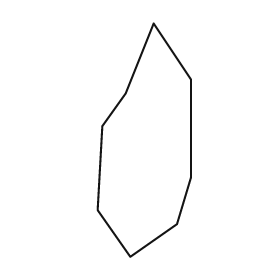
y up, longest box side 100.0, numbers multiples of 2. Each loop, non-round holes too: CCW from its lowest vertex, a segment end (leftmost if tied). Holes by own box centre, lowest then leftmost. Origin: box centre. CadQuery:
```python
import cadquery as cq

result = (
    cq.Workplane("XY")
    .moveTo(-6.0, -50.0)
    .lineTo(14.0, -36.0)
    .lineTo(20.0, -16.0)
    .lineTo(20.0, 26.0)
    .lineTo(4.0, 50.0)
    .lineTo(-8.0, 20.0)
    .lineTo(-18.0, 6.0)
    .lineTo(-20.0, -30.0)
    .close()
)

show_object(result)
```